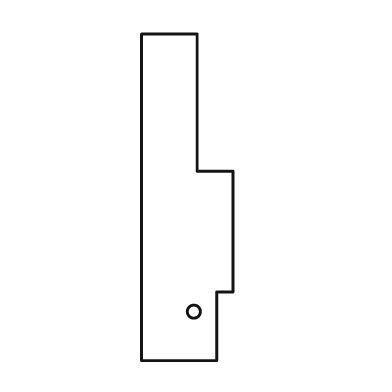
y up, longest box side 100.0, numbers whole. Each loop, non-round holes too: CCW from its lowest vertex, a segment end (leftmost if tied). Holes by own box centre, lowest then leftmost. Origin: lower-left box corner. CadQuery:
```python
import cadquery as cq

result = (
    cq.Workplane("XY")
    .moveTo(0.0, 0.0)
    .lineTo(23.0, 0.0)
    .lineTo(23.0, 21.0)
    .lineTo(28.0, 21.0)
    .lineTo(28.0, 58.0)
    .lineTo(17.0, 58.0)
    .lineTo(17.0, 100.0)
    .lineTo(0.0, 100.0)
    .close()
    .moveTo(16.0, 15.0)
    .circle(2.0)
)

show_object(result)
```